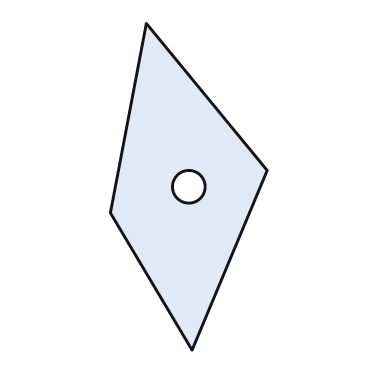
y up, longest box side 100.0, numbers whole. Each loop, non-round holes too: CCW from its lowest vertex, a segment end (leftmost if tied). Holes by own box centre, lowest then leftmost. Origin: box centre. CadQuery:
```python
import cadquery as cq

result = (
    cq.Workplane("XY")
    .moveTo(1.0, -50.0)
    .lineTo(24.0, 5.0)
    .lineTo(-13.0, 50.0)
    .lineTo(-24.0, -8.0)
    .close()
    .moveTo(0.0, 0.0)
    .circle(5.0)
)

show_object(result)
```